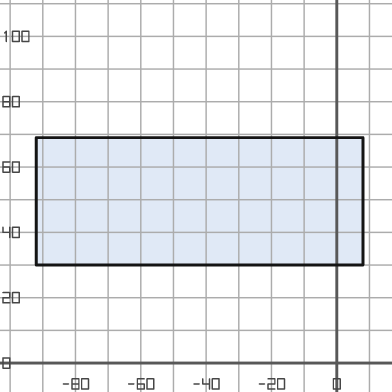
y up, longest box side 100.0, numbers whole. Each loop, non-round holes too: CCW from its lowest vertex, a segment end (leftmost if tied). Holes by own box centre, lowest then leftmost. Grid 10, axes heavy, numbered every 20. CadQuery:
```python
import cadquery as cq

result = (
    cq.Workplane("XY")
    .moveTo(-92.0, 30.0)
    .lineTo(8.0, 30.0)
    .lineTo(8.0, 69.0)
    .lineTo(-92.0, 69.0)
    .close()
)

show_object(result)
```